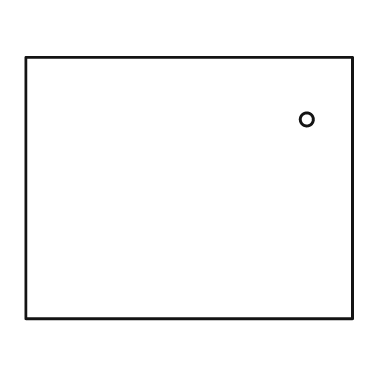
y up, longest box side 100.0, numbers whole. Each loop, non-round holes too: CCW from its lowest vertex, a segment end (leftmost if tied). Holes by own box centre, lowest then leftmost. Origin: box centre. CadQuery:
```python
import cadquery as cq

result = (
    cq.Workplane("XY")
    .moveTo(-50.0, -40.0)
    .lineTo(50.0, -40.0)
    .lineTo(50.0, 40.0)
    .lineTo(-50.0, 40.0)
    .close()
    .moveTo(36.0, 21.0)
    .circle(2.0)
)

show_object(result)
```